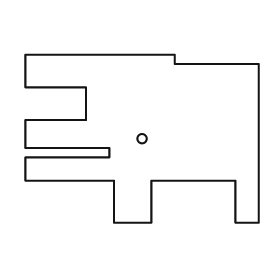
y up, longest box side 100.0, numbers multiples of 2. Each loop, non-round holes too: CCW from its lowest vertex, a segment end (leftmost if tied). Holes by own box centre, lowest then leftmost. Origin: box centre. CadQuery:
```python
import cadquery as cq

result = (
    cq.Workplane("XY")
    .moveTo(-12.0, -36.0)
    .lineTo(4.0, -36.0)
    .lineTo(4.0, -18.0)
    .lineTo(40.0, -18.0)
    .lineTo(40.0, -36.0)
    .lineTo(50.0, -36.0)
    .lineTo(50.0, 32.0)
    .lineTo(14.0, 32.0)
    .lineTo(14.0, 36.0)
    .lineTo(-50.0, 36.0)
    .lineTo(-50.0, 22.0)
    .lineTo(-24.0, 22.0)
    .lineTo(-24.0, 8.0)
    .lineTo(-50.0, 8.0)
    .lineTo(-50.0, -4.0)
    .lineTo(-14.0, -4.0)
    .lineTo(-14.0, -8.0)
    .lineTo(-50.0, -8.0)
    .lineTo(-50.0, -18.0)
    .lineTo(-12.0, -18.0)
    .close()
    .moveTo(0.0, 0.0)
    .circle(2.0)
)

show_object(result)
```